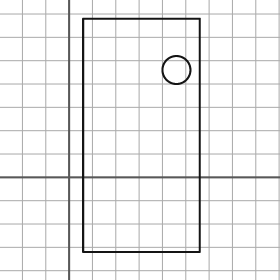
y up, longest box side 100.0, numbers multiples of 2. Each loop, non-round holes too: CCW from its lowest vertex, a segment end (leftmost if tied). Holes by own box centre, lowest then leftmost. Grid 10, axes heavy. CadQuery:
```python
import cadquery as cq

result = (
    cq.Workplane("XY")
    .moveTo(6.0, -32.0)
    .lineTo(56.0, -32.0)
    .lineTo(56.0, 68.0)
    .lineTo(6.0, 68.0)
    .close()
    .moveTo(46.0, 46.0)
    .circle(6.0)
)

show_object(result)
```